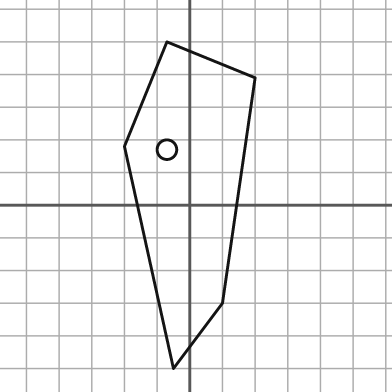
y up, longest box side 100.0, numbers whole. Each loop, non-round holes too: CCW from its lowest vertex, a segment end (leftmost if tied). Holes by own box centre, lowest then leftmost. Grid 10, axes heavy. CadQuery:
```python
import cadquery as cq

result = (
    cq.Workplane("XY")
    .moveTo(-5.0, -50.0)
    .lineTo(10.0, -30.0)
    .lineTo(20.0, 39.0)
    .lineTo(-7.0, 50.0)
    .lineTo(-20.0, 18.0)
    .close()
    .moveTo(-7.0, 17.0)
    .circle(3.0)
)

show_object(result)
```